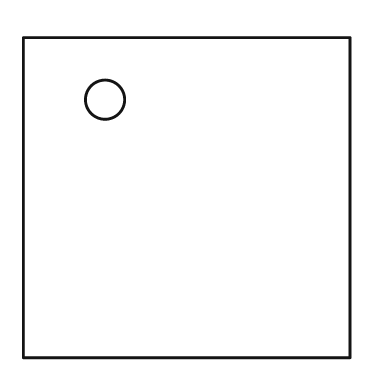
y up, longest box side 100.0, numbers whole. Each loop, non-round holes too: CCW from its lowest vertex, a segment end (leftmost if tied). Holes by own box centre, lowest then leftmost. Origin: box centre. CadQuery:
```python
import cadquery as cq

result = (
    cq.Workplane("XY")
    .moveTo(-50.0, -49.0)
    .lineTo(50.0, -49.0)
    .lineTo(50.0, 49.0)
    .lineTo(-50.0, 49.0)
    .close()
    .moveTo(-25.0, 30.0)
    .circle(6.0)
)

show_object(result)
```